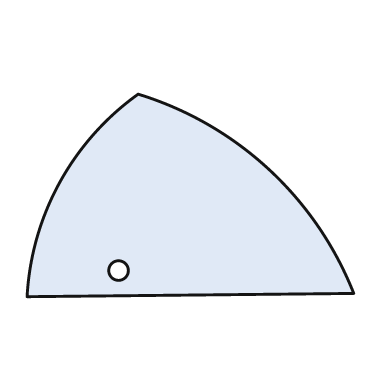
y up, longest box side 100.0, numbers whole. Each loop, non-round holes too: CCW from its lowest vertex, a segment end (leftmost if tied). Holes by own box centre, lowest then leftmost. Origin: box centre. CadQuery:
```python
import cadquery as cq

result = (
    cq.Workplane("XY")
    .moveTo(-50.0, -31.0)
    .lineTo(50.0, -30.0)
    .threePointArc((24.0, 8.0), (-16.0, 31.0))
    .threePointArc((-40.0, 4.0), (-50.0, -31.0))
    .close()
    .moveTo(-22.0, -23.0)
    .circle(3.0)
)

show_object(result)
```